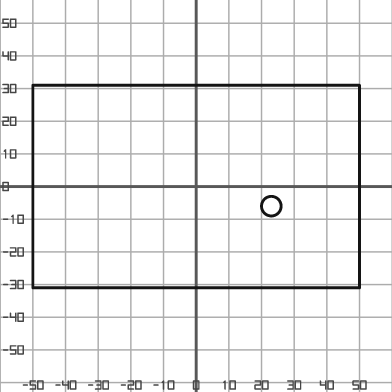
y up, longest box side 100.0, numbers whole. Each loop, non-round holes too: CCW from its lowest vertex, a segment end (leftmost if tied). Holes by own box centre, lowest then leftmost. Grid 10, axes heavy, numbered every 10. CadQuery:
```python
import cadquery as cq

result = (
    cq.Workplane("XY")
    .moveTo(-50.0, -31.0)
    .lineTo(50.0, -31.0)
    .lineTo(50.0, 31.0)
    .lineTo(-50.0, 31.0)
    .close()
    .moveTo(23.0, -6.0)
    .circle(3.0)
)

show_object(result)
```